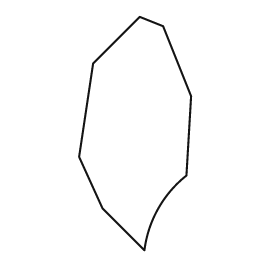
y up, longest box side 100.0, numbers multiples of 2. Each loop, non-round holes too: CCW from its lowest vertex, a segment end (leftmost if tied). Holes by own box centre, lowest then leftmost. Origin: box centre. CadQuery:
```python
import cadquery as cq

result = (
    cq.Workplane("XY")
    .moveTo(4.0, -50.0)
    .threePointArc((10.0, -32.0), (22.0, -18.0))
    .lineTo(24.0, 16.0)
    .lineTo(12.0, 46.0)
    .lineTo(2.0, 50.0)
    .lineTo(-18.0, 30.0)
    .lineTo(-24.0, -10.0)
    .lineTo(-14.0, -32.0)
    .close()
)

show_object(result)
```